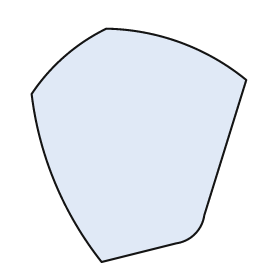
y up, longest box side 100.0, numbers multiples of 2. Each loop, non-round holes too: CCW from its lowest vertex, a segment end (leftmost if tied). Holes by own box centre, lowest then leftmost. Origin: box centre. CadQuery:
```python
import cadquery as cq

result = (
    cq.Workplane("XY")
    .moveTo(-16.0, -50.0)
    .lineTo(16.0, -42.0)
    .threePointArc((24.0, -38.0), (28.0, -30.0))
    .lineTo(46.0, 28.0)
    .threePointArc((18.0, 44.0), (-14.0, 50.0))
    .threePointArc((-32.0, 38.0), (-46.0, 22.0))
    .threePointArc((-36.0, -16.0), (-16.0, -50.0))
    .close()
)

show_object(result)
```